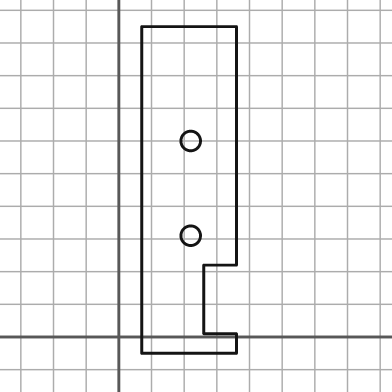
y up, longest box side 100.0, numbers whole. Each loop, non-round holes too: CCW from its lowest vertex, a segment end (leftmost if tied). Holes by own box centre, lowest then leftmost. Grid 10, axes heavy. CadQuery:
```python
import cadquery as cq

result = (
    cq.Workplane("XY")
    .moveTo(7.0, -5.0)
    .lineTo(36.0, -5.0)
    .lineTo(36.0, 1.0)
    .lineTo(26.0, 1.0)
    .lineTo(26.0, 22.0)
    .lineTo(36.0, 22.0)
    .lineTo(36.0, 95.0)
    .lineTo(7.0, 95.0)
    .close()
    .moveTo(22.0, 31.0)
    .circle(3.0)
    .moveTo(22.0, 60.0)
    .circle(3.0)
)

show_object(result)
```